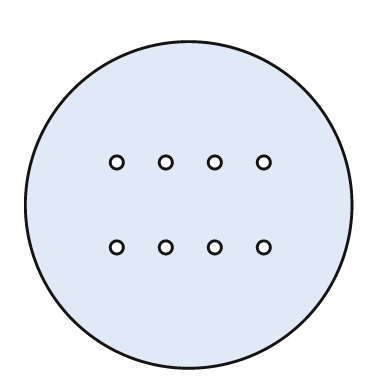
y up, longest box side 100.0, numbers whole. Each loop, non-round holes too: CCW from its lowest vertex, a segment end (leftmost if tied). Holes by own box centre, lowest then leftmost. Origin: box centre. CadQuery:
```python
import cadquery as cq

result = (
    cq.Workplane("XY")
    .moveTo(0.0, 0.0)
    .circle(50.0)
    .moveTo(-22.0, -13.0)
    .circle(2.0)
    .moveTo(-7.0, -13.0)
    .circle(2.0)
    .moveTo(8.0, -13.0)
    .circle(2.0)
    .moveTo(23.0, -13.0)
    .circle(2.0)
    .moveTo(-22.0, 13.0)
    .circle(2.0)
    .moveTo(-7.0, 13.0)
    .circle(2.0)
    .moveTo(8.0, 13.0)
    .circle(2.0)
    .moveTo(23.0, 13.0)
    .circle(2.0)
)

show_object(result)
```